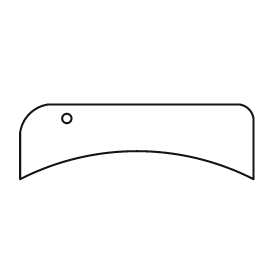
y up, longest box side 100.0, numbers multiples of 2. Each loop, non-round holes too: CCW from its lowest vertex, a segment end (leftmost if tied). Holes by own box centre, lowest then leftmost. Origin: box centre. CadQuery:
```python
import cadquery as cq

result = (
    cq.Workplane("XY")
    .moveTo(-50.0, -16.0)
    .threePointArc((0.0, -4.0), (50.0, -16.0))
    .lineTo(50.0, 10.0)
    .threePointArc((48.0, 14.0), (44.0, 16.0))
    .lineTo(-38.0, 16.0)
    .threePointArc((-46.0, 12.0), (-50.0, 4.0))
    .close()
    .moveTo(-30.0, 10.0)
    .circle(2.0)
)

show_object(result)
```